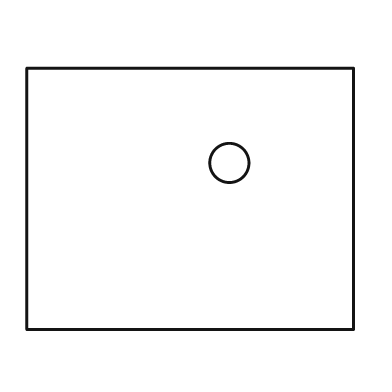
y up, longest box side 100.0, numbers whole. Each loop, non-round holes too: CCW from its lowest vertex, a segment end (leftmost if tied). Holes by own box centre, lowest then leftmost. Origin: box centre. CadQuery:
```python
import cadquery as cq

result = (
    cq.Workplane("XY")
    .moveTo(-50.0, -40.0)
    .lineTo(50.0, -40.0)
    .lineTo(50.0, 40.0)
    .lineTo(-50.0, 40.0)
    .close()
    .moveTo(12.0, 11.0)
    .circle(6.0)
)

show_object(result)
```